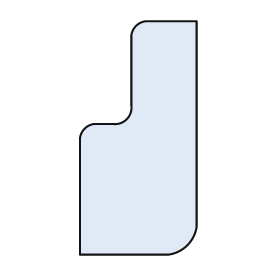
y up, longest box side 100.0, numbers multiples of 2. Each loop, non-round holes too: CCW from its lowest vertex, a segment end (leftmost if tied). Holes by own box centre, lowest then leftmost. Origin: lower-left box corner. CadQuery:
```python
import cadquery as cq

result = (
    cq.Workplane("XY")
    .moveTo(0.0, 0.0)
    .lineTo(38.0, 0.0)
    .threePointArc((46.0, 4.0), (50.0, 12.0))
    .lineTo(50.0, 100.0)
    .lineTo(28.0, 100.0)
    .threePointArc((24.0, 98.0), (22.0, 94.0))
    .lineTo(22.0, 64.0)
    .threePointArc((20.0, 58.0), (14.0, 56.0))
    .lineTo(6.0, 56.0)
    .threePointArc((2.0, 54.0), (0.0, 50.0))
    .close()
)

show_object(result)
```